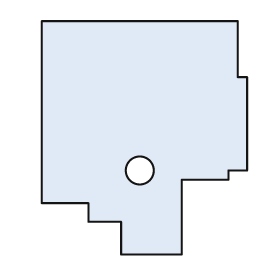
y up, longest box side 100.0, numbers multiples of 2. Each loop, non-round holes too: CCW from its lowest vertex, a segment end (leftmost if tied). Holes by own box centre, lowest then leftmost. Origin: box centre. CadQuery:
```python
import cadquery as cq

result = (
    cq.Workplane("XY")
    .moveTo(-10.0, -50.0)
    .lineTo(16.0, -50.0)
    .lineTo(16.0, -18.0)
    .lineTo(36.0, -18.0)
    .lineTo(36.0, -14.0)
    .lineTo(44.0, -14.0)
    .lineTo(44.0, 26.0)
    .lineTo(40.0, 26.0)
    .lineTo(40.0, 50.0)
    .lineTo(-44.0, 50.0)
    .lineTo(-44.0, -28.0)
    .lineTo(-24.0, -28.0)
    .lineTo(-24.0, -36.0)
    .lineTo(-10.0, -36.0)
    .close()
    .moveTo(-2.0, -14.0)
    .circle(6.0)
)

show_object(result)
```